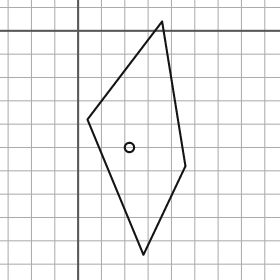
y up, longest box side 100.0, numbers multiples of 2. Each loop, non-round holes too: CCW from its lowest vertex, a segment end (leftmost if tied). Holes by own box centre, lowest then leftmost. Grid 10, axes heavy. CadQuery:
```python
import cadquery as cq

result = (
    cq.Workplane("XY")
    .moveTo(28.0, -96.0)
    .lineTo(46.0, -58.0)
    .lineTo(36.0, 4.0)
    .lineTo(4.0, -38.0)
    .close()
    .moveTo(22.0, -50.0)
    .circle(2.0)
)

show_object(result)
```